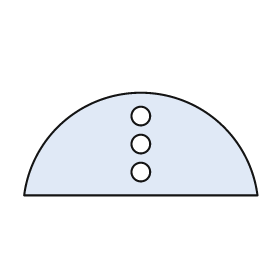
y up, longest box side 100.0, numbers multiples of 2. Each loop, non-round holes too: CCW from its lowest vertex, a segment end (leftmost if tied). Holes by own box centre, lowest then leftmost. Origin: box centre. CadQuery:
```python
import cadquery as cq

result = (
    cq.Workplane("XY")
    .moveTo(-50.0, -22.0)
    .lineTo(50.0, -22.0)
    .threePointArc((0.0, 22.0), (-50.0, -22.0))
    .close()
    .moveTo(0.0, -12.0)
    .circle(4.0)
    .moveTo(0.0, 0.0)
    .circle(4.0)
    .moveTo(0.0, 12.0)
    .circle(4.0)
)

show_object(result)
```